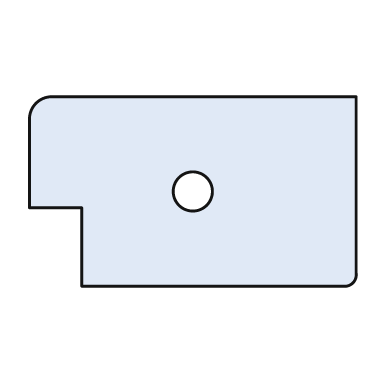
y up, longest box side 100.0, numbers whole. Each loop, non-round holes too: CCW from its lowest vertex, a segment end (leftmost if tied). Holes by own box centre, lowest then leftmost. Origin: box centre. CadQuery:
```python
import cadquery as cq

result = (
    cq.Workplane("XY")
    .moveTo(-34.0, -29.0)
    .lineTo(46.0, -29.0)
    .threePointArc((49.0, -28.0), (50.0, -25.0))
    .lineTo(50.0, 29.0)
    .lineTo(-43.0, 29.0)
    .threePointArc((-48.0, 27.0), (-50.0, 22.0))
    .lineTo(-50.0, -5.0)
    .lineTo(-34.0, -5.0)
    .close()
    .moveTo(0.0, 0.0)
    .circle(6.0)
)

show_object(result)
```